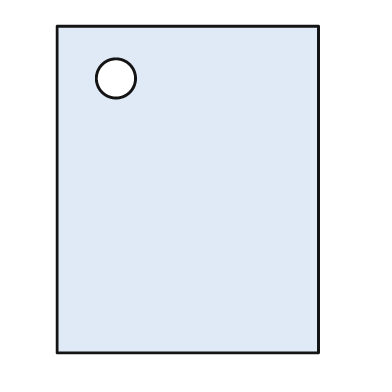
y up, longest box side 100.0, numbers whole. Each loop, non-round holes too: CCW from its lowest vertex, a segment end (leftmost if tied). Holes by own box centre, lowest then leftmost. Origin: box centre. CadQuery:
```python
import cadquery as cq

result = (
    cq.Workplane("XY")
    .moveTo(-40.0, -50.0)
    .lineTo(40.0, -50.0)
    .lineTo(40.0, 50.0)
    .lineTo(-40.0, 50.0)
    .close()
    .moveTo(-22.0, 34.0)
    .circle(6.0)
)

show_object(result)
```